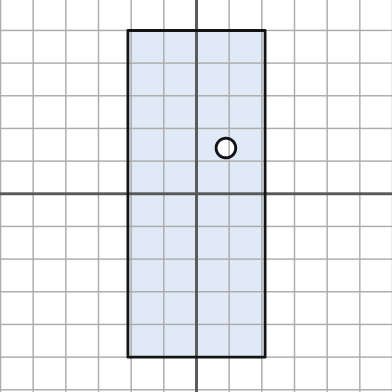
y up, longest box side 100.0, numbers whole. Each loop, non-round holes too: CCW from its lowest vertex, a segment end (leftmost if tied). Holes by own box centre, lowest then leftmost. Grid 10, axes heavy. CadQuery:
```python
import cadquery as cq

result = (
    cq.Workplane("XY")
    .moveTo(-21.0, -50.0)
    .lineTo(21.0, -50.0)
    .lineTo(21.0, 50.0)
    .lineTo(-21.0, 50.0)
    .close()
    .moveTo(9.0, 14.0)
    .circle(3.0)
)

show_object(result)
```